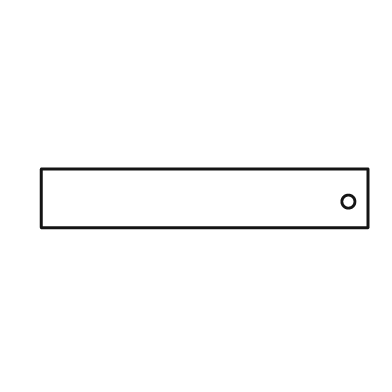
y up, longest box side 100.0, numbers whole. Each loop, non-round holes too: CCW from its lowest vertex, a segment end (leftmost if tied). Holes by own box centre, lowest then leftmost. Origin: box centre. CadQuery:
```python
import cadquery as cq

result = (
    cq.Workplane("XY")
    .moveTo(-50.0, -9.0)
    .lineTo(50.0, -9.0)
    .lineTo(50.0, 9.0)
    .lineTo(-50.0, 9.0)
    .close()
    .moveTo(44.0, -1.0)
    .circle(2.0)
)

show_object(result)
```